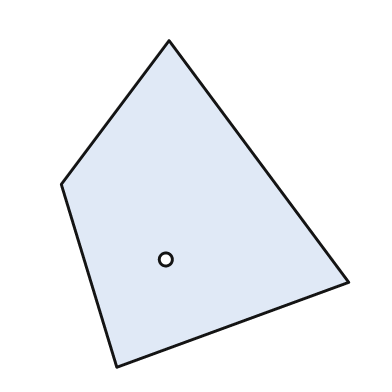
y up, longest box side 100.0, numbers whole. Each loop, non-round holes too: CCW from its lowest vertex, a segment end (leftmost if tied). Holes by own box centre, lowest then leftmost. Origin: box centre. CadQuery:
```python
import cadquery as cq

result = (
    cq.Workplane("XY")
    .moveTo(-27.0, -50.0)
    .lineTo(44.0, -24.0)
    .lineTo(-11.0, 50.0)
    .lineTo(-44.0, 6.0)
    .close()
    .moveTo(-12.0, -17.0)
    .circle(2.0)
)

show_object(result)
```